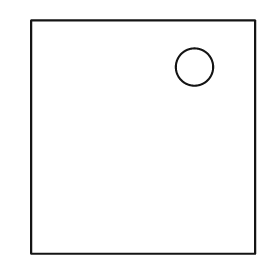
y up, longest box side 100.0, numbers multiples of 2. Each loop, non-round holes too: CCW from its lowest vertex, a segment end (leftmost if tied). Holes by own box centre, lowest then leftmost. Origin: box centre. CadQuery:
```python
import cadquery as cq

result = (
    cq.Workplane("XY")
    .moveTo(-48.0, -50.0)
    .lineTo(48.0, -50.0)
    .lineTo(48.0, 50.0)
    .lineTo(-48.0, 50.0)
    .close()
    .moveTo(22.0, 30.0)
    .circle(8.0)
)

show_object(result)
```